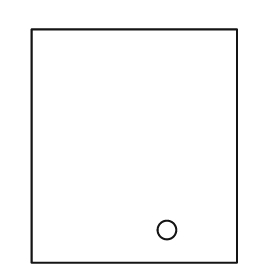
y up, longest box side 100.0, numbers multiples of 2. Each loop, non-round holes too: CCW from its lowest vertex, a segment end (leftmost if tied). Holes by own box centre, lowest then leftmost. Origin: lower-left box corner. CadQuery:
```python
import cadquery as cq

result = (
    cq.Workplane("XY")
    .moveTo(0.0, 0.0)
    .lineTo(88.0, 0.0)
    .lineTo(88.0, 100.0)
    .lineTo(0.0, 100.0)
    .close()
    .moveTo(58.0, 14.0)
    .circle(4.0)
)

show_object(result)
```